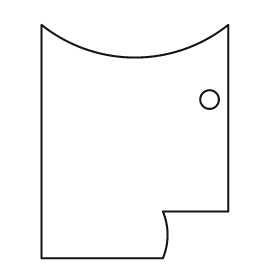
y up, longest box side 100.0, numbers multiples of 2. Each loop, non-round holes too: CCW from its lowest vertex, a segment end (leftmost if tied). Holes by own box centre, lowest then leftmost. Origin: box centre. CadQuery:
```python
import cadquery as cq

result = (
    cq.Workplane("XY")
    .moveTo(-40.0, -50.0)
    .lineTo(12.0, -50.0)
    .threePointArc((14.0, -40.0), (12.0, -30.0))
    .lineTo(40.0, -30.0)
    .lineTo(40.0, 50.0)
    .threePointArc((0.0, 36.0), (-40.0, 50.0))
    .close()
    .moveTo(32.0, 18.0)
    .circle(4.0)
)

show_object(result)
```